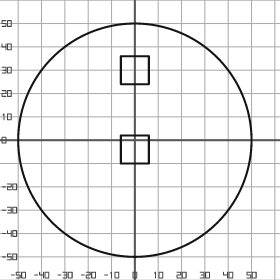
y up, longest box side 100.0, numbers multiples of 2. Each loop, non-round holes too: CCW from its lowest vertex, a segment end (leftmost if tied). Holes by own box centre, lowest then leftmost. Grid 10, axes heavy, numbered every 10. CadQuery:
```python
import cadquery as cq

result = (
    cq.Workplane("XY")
    .moveTo(0.0, 0.0)
    .circle(50.0)
    .moveTo(-6.0, -10.0)
    .lineTo(6.0, -10.0)
    .lineTo(6.0, 2.0)
    .lineTo(-6.0, 2.0)
    .close()
    .moveTo(-6.0, 24.0)
    .lineTo(6.0, 24.0)
    .lineTo(6.0, 36.0)
    .lineTo(-6.0, 36.0)
    .close()
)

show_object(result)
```